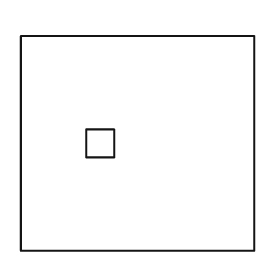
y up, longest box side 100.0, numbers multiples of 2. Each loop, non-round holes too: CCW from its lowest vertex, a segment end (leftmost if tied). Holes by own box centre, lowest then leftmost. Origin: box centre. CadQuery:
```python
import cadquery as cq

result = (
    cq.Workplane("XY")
    .moveTo(-50.0, -46.0)
    .lineTo(50.0, -46.0)
    .lineTo(50.0, 46.0)
    .lineTo(-50.0, 46.0)
    .close()
    .moveTo(-22.0, -6.0)
    .lineTo(-10.0, -6.0)
    .lineTo(-10.0, 6.0)
    .lineTo(-22.0, 6.0)
    .close()
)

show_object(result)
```